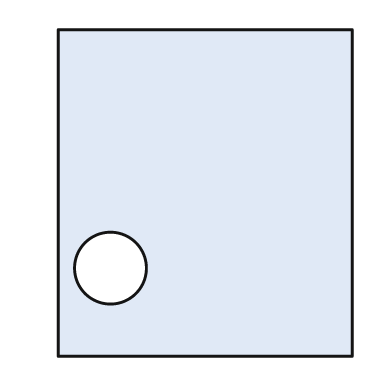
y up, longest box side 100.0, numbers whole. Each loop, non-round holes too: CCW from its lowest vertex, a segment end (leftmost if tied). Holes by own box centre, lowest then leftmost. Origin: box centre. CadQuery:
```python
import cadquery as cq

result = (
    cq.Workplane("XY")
    .moveTo(-45.0, -50.0)
    .lineTo(45.0, -50.0)
    .lineTo(45.0, 50.0)
    .lineTo(-45.0, 50.0)
    .close()
    .moveTo(-29.0, -23.0)
    .circle(11.0)
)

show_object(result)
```